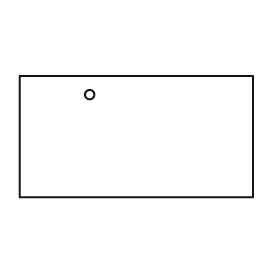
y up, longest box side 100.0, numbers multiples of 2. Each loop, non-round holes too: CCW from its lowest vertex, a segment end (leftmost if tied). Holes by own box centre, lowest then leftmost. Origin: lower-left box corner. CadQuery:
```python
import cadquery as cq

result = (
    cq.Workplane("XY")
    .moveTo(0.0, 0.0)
    .lineTo(100.0, 0.0)
    .lineTo(100.0, 52.0)
    .lineTo(0.0, 52.0)
    .close()
    .moveTo(30.0, 44.0)
    .circle(2.0)
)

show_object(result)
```